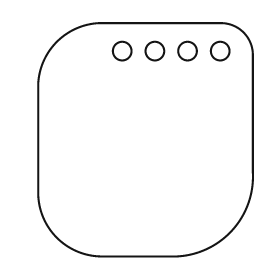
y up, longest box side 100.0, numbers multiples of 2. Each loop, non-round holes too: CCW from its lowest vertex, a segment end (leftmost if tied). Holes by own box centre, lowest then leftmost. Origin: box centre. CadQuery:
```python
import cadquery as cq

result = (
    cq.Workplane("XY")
    .moveTo(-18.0, -50.0)
    .lineTo(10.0, -50.0)
    .threePointArc((36.0, -40.0), (46.0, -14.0))
    .lineTo(46.0, 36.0)
    .threePointArc((42.0, 46.0), (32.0, 50.0))
    .lineTo(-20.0, 50.0)
    .threePointArc((-38.0, 42.0), (-46.0, 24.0))
    .lineTo(-46.0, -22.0)
    .threePointArc((-38.0, -42.0), (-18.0, -50.0))
    .close()
    .moveTo(-10.0, 38.0)
    .circle(4.0)
    .moveTo(4.0, 38.0)
    .circle(4.0)
    .moveTo(18.0, 38.0)
    .circle(4.0)
    .moveTo(32.0, 38.0)
    .circle(4.0)
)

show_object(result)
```